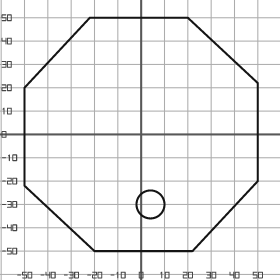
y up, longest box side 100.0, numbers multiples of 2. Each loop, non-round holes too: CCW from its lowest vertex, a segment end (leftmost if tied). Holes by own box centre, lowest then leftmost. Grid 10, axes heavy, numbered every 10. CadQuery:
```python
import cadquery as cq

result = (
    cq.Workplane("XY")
    .moveTo(-20.0, -50.0)
    .lineTo(22.0, -50.0)
    .lineTo(50.0, -20.0)
    .lineTo(50.0, 22.0)
    .lineTo(20.0, 50.0)
    .lineTo(-22.0, 50.0)
    .lineTo(-50.0, 20.0)
    .lineTo(-50.0, -22.0)
    .close()
    .moveTo(4.0, -30.0)
    .circle(6.0)
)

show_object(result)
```